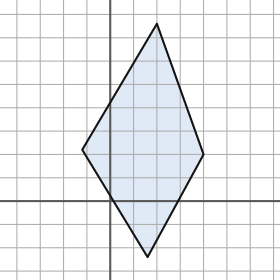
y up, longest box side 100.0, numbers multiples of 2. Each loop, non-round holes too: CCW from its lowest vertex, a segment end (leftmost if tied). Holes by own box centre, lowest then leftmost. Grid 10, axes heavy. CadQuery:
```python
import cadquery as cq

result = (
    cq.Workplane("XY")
    .moveTo(16.0, -24.0)
    .lineTo(40.0, 20.0)
    .lineTo(20.0, 76.0)
    .lineTo(-12.0, 22.0)
    .close()
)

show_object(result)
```